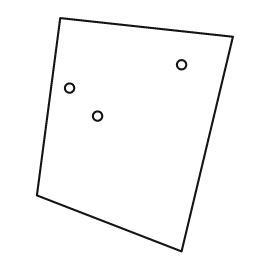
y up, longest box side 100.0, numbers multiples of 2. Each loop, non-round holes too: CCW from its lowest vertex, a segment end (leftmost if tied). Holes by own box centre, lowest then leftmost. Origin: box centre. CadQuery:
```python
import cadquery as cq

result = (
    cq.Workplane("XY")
    .moveTo(20.0, -50.0)
    .lineTo(42.0, 42.0)
    .lineTo(-32.0, 50.0)
    .lineTo(-42.0, -26.0)
    .close()
    .moveTo(-16.0, 8.0)
    .circle(2.0)
    .moveTo(-28.0, 20.0)
    .circle(2.0)
    .moveTo(20.0, 30.0)
    .circle(2.0)
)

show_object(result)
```